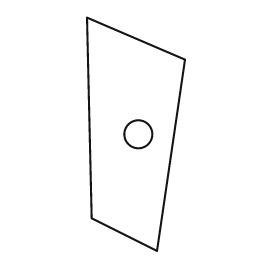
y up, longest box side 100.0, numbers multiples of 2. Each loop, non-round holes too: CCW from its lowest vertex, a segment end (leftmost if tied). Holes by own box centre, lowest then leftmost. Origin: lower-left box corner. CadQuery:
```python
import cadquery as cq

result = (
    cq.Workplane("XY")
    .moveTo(30.0, 0.0)
    .lineTo(42.0, 82.0)
    .lineTo(0.0, 100.0)
    .lineTo(2.0, 14.0)
    .close()
    .moveTo(22.0, 50.0)
    .circle(6.0)
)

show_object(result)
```